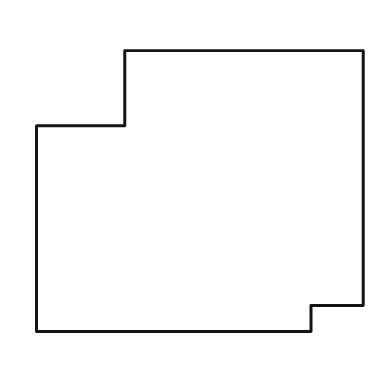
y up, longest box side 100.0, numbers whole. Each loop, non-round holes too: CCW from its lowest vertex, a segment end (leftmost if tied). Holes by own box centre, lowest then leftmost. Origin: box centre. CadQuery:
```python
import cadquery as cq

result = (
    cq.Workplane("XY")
    .moveTo(-50.0, -43.0)
    .lineTo(34.0, -43.0)
    .lineTo(34.0, -35.0)
    .lineTo(50.0, -35.0)
    .lineTo(50.0, 43.0)
    .lineTo(-23.0, 43.0)
    .lineTo(-23.0, 20.0)
    .lineTo(-50.0, 20.0)
    .close()
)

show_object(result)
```